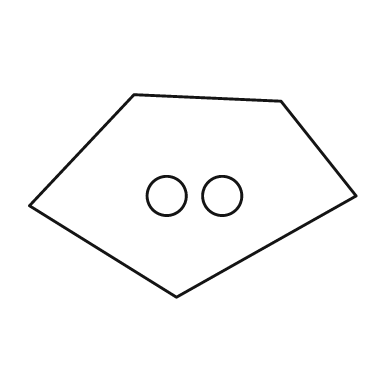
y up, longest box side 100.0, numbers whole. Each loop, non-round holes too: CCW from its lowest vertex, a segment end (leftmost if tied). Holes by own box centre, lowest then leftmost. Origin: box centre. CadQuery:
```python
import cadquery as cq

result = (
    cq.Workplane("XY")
    .moveTo(-5.0, -31.0)
    .lineTo(50.0, 0.0)
    .lineTo(27.0, 29.0)
    .lineTo(-18.0, 31.0)
    .lineTo(-50.0, -3.0)
    .close()
    .moveTo(-8.0, 0.0)
    .circle(6.0)
    .moveTo(9.0, 0.0)
    .circle(6.0)
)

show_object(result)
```